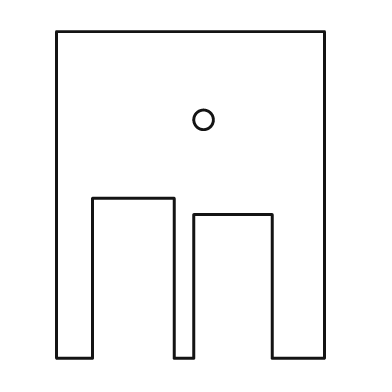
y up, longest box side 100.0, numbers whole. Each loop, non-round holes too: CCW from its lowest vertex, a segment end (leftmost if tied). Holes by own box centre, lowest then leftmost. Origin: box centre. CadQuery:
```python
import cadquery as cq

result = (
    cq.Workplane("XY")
    .moveTo(-41.0, -50.0)
    .lineTo(-30.0, -50.0)
    .lineTo(-30.0, -1.0)
    .lineTo(-5.0, -1.0)
    .lineTo(-5.0, -50.0)
    .lineTo(1.0, -50.0)
    .lineTo(1.0, -6.0)
    .lineTo(25.0, -6.0)
    .lineTo(25.0, -50.0)
    .lineTo(41.0, -50.0)
    .lineTo(41.0, 50.0)
    .lineTo(-41.0, 50.0)
    .close()
    .moveTo(4.0, 23.0)
    .circle(3.0)
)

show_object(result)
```